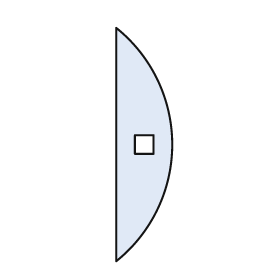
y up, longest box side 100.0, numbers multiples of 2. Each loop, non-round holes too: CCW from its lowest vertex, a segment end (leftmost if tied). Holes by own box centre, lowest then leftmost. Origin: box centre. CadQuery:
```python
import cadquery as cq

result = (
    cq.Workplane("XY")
    .moveTo(-12.0, -50.0)
    .threePointArc((12.0, 0.0), (-12.0, 50.0))
    .close()
    .moveTo(-4.0, -4.0)
    .lineTo(4.0, -4.0)
    .lineTo(4.0, 4.0)
    .lineTo(-4.0, 4.0)
    .close()
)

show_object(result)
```